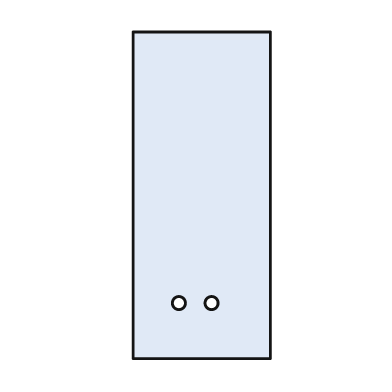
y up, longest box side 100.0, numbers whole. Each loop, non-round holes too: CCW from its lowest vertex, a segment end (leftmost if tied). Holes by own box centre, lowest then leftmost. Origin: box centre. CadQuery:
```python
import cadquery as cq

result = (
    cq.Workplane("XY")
    .moveTo(-21.0, -50.0)
    .lineTo(21.0, -50.0)
    .lineTo(21.0, 50.0)
    .lineTo(-21.0, 50.0)
    .close()
    .moveTo(-7.0, -33.0)
    .circle(2.0)
    .moveTo(3.0, -33.0)
    .circle(2.0)
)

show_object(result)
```